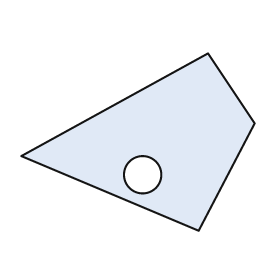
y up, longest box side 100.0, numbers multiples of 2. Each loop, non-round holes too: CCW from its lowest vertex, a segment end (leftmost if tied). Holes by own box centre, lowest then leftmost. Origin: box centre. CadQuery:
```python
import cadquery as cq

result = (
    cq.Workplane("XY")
    .moveTo(26.0, -38.0)
    .lineTo(50.0, 8.0)
    .lineTo(30.0, 38.0)
    .lineTo(-50.0, -6.0)
    .close()
    .moveTo(2.0, -14.0)
    .circle(8.0)
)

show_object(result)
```